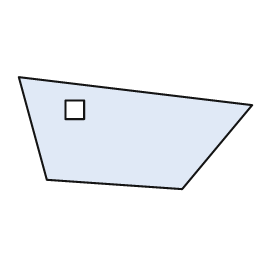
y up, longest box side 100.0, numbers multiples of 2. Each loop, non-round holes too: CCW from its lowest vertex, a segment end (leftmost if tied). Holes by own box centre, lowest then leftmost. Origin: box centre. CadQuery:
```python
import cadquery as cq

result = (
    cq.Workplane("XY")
    .moveTo(20.0, -24.0)
    .lineTo(50.0, 12.0)
    .lineTo(-50.0, 24.0)
    .lineTo(-38.0, -20.0)
    .close()
    .moveTo(-30.0, 6.0)
    .lineTo(-22.0, 6.0)
    .lineTo(-22.0, 14.0)
    .lineTo(-30.0, 14.0)
    .close()
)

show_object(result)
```